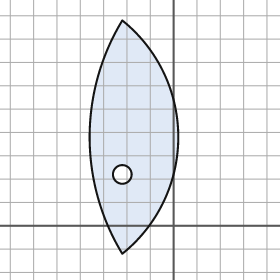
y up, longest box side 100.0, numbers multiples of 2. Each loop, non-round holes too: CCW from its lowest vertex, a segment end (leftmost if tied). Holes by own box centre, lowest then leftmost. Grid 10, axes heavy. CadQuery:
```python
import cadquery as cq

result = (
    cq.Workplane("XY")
    .moveTo(-22.0, -12.0)
    .threePointArc((2.0, 38.0), (-22.0, 88.0))
    .threePointArc((-36.0, 38.0), (-22.0, -12.0))
    .close()
    .moveTo(-22.0, 22.0)
    .circle(4.0)
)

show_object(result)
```